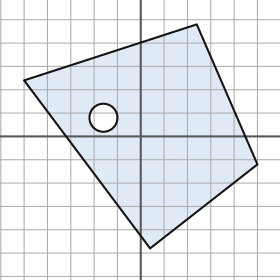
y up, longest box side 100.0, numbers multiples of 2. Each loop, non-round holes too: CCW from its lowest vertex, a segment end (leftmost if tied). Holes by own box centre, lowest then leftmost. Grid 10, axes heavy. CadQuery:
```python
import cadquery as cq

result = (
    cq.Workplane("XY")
    .moveTo(4.0, -48.0)
    .lineTo(50.0, -12.0)
    .lineTo(24.0, 48.0)
    .lineTo(-50.0, 24.0)
    .close()
    .moveTo(-16.0, 8.0)
    .circle(6.0)
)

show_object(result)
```